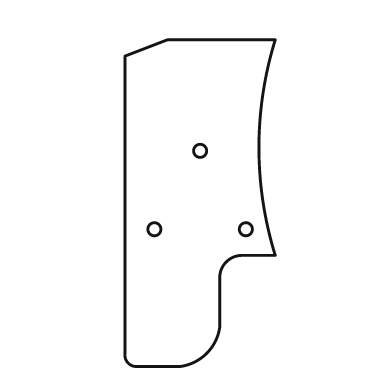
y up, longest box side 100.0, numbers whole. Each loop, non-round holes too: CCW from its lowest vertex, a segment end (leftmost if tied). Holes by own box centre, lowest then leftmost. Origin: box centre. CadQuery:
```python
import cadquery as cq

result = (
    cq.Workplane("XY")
    .moveTo(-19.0, -50.0)
    .lineTo(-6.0, -50.0)
    .threePointArc((2.0, -46.0), (6.0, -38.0))
    .lineTo(6.0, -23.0)
    .threePointArc((8.0, -18.0), (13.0, -16.0))
    .lineTo(23.0, -16.0)
    .threePointArc((18.0, 17.0), (23.0, 50.0))
    .lineTo(-10.0, 50.0)
    .lineTo(-23.0, 45.0)
    .lineTo(-23.0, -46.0)
    .threePointArc((-22.0, -49.0), (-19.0, -50.0))
    .close()
    .moveTo(-14.0, -8.0)
    .circle(2.0)
    .moveTo(14.0, -8.0)
    .circle(2.0)
    .moveTo(0.0, 16.0)
    .circle(2.0)
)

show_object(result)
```